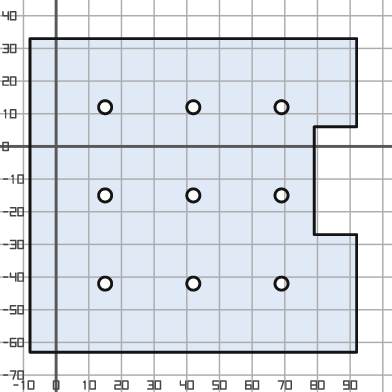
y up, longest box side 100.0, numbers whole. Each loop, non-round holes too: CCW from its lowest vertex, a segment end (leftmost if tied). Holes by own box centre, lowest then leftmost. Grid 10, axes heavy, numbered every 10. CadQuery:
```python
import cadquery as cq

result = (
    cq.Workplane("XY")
    .moveTo(-8.0, -63.0)
    .lineTo(92.0, -63.0)
    .lineTo(92.0, -27.0)
    .lineTo(79.0, -27.0)
    .lineTo(79.0, 6.0)
    .lineTo(92.0, 6.0)
    .lineTo(92.0, 33.0)
    .lineTo(-8.0, 33.0)
    .close()
    .moveTo(15.0, -42.0)
    .circle(2.0)
    .moveTo(42.0, -42.0)
    .circle(2.0)
    .moveTo(69.0, -42.0)
    .circle(2.0)
    .moveTo(15.0, -15.0)
    .circle(2.0)
    .moveTo(42.0, -15.0)
    .circle(2.0)
    .moveTo(69.0, -15.0)
    .circle(2.0)
    .moveTo(15.0, 12.0)
    .circle(2.0)
    .moveTo(42.0, 12.0)
    .circle(2.0)
    .moveTo(69.0, 12.0)
    .circle(2.0)
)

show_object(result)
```